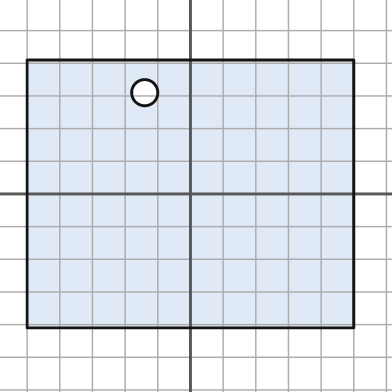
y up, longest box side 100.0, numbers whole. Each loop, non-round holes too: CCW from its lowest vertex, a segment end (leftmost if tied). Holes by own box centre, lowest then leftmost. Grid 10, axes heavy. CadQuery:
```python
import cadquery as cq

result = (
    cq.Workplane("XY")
    .moveTo(-50.0, -41.0)
    .lineTo(50.0, -41.0)
    .lineTo(50.0, 41.0)
    .lineTo(-50.0, 41.0)
    .close()
    .moveTo(-14.0, 31.0)
    .circle(4.0)
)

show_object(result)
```